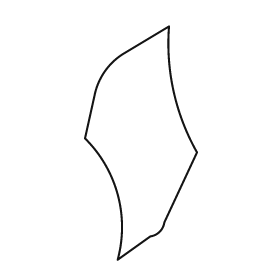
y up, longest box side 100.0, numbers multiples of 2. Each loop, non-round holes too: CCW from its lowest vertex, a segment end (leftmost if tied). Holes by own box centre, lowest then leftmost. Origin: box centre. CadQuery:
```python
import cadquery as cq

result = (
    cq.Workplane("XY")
    .moveTo(-10.0, -50.0)
    .lineTo(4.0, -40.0)
    .threePointArc((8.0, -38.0), (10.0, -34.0))
    .lineTo(24.0, -4.0)
    .threePointArc((14.0, 22.0), (12.0, 50.0))
    .lineTo(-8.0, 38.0)
    .threePointArc((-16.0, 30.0), (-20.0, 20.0))
    .lineTo(-24.0, 2.0)
    .threePointArc((-10.0, -22.0), (-10.0, -50.0))
    .close()
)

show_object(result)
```